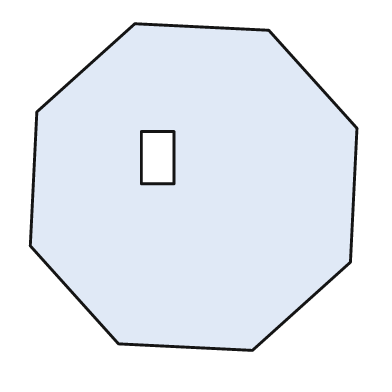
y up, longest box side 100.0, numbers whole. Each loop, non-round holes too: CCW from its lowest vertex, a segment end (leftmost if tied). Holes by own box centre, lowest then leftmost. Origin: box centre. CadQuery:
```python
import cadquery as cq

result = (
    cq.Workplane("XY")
    .moveTo(18.0, -50.0)
    .lineTo(48.0, -23.0)
    .lineTo(50.0, 18.0)
    .lineTo(23.0, 48.0)
    .lineTo(-18.0, 50.0)
    .lineTo(-48.0, 23.0)
    .lineTo(-50.0, -18.0)
    .lineTo(-23.0, -48.0)
    .close()
    .moveTo(-16.0, 1.0)
    .lineTo(-6.0, 1.0)
    .lineTo(-6.0, 17.0)
    .lineTo(-16.0, 17.0)
    .close()
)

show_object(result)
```